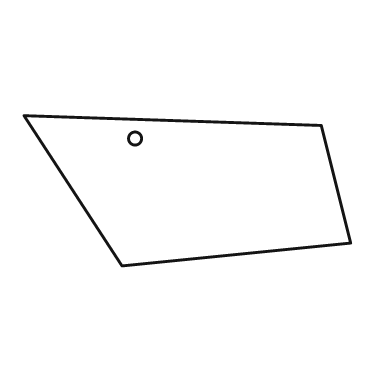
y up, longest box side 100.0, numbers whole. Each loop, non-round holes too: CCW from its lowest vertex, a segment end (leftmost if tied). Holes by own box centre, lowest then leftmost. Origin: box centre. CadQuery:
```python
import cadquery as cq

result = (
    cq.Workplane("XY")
    .moveTo(-20.0, -23.0)
    .lineTo(50.0, -16.0)
    .lineTo(41.0, 20.0)
    .lineTo(-50.0, 23.0)
    .close()
    .moveTo(-16.0, 16.0)
    .circle(2.0)
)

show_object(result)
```